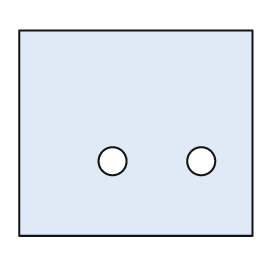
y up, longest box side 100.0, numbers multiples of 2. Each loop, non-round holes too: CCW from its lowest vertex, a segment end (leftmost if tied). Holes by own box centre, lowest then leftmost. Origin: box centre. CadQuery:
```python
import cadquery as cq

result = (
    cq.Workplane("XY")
    .moveTo(-50.0, -44.0)
    .lineTo(50.0, -44.0)
    .lineTo(50.0, 44.0)
    .lineTo(-50.0, 44.0)
    .close()
    .moveTo(-10.0, -12.0)
    .circle(6.0)
    .moveTo(28.0, -12.0)
    .circle(6.0)
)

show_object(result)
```